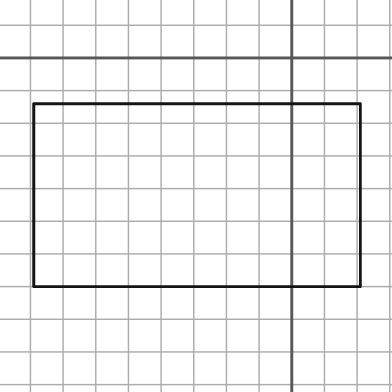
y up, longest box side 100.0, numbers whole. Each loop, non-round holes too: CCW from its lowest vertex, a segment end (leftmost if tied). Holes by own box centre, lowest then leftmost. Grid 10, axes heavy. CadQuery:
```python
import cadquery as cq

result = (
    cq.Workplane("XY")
    .moveTo(-79.0, -70.0)
    .lineTo(21.0, -70.0)
    .lineTo(21.0, -14.0)
    .lineTo(-79.0, -14.0)
    .close()
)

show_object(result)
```